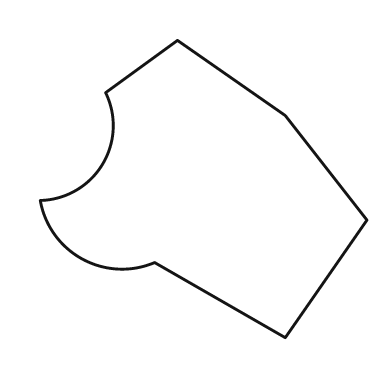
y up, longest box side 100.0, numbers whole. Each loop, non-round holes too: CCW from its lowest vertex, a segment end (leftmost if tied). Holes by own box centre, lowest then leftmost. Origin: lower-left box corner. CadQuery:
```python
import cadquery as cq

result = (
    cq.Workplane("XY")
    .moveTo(75.0, 0.0)
    .lineTo(100.0, 36.0)
    .lineTo(75.0, 68.0)
    .lineTo(42.0, 91.0)
    .lineTo(20.0, 75.0)
    .threePointArc((19.0, 53.0), (0.0, 42.0))
    .threePointArc((13.0, 24.0), (35.0, 23.0))
    .close()
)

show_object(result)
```